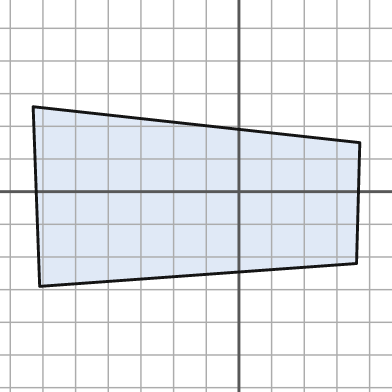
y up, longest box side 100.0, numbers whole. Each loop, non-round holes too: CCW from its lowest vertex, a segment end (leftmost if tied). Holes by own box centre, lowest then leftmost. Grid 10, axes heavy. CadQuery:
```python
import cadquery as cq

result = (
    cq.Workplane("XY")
    .moveTo(-61.0, -29.0)
    .lineTo(36.0, -22.0)
    .lineTo(37.0, 15.0)
    .lineTo(-63.0, 26.0)
    .close()
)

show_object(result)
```